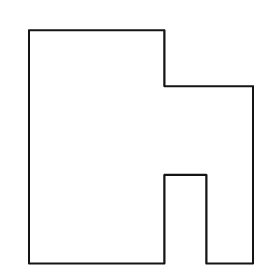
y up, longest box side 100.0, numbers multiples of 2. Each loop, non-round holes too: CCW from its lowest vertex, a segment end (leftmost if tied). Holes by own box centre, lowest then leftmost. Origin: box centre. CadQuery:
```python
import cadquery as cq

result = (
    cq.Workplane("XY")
    .moveTo(-48.0, -50.0)
    .lineTo(10.0, -50.0)
    .lineTo(10.0, -12.0)
    .lineTo(28.0, -12.0)
    .lineTo(28.0, -50.0)
    .lineTo(48.0, -50.0)
    .lineTo(48.0, 26.0)
    .lineTo(10.0, 26.0)
    .lineTo(10.0, 50.0)
    .lineTo(-48.0, 50.0)
    .close()
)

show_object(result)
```